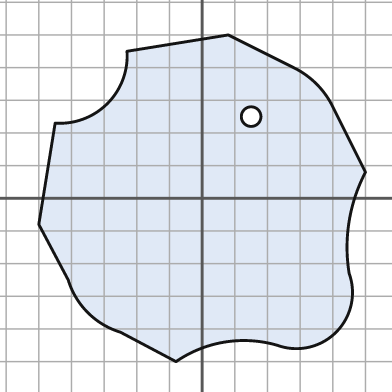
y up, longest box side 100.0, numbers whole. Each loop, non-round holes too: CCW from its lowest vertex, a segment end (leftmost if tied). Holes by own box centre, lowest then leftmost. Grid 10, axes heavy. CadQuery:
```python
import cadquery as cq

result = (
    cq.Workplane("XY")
    .moveTo(-8.0, -50.0)
    .threePointArc((7.0, -44.0), (23.0, -45.0))
    .threePointArc((41.0, -41.0), (45.0, -23.0))
    .threePointArc((45.0, -7.0), (50.0, 8.0))
    .lineTo(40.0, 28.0)
    .threePointArc((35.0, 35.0), (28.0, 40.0))
    .lineTo(8.0, 50.0)
    .lineTo(-23.0, 45.0)
    .threePointArc((-29.0, 29.0), (-45.0, 23.0))
    .lineTo(-50.0, -8.0)
    .lineTo(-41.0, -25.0)
    .threePointArc((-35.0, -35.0), (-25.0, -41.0))
    .close()
    .moveTo(15.0, 25.0)
    .circle(3.0)
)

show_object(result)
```